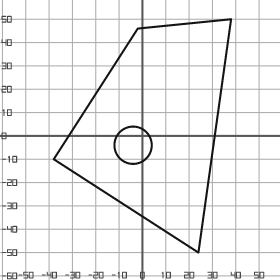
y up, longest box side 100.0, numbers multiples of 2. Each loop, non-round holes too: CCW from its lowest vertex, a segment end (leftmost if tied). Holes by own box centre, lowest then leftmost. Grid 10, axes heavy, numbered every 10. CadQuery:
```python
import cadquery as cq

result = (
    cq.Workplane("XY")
    .moveTo(24.0, -50.0)
    .lineTo(38.0, 50.0)
    .lineTo(-2.0, 46.0)
    .lineTo(-38.0, -10.0)
    .close()
    .moveTo(-4.0, -4.0)
    .circle(8.0)
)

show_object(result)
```